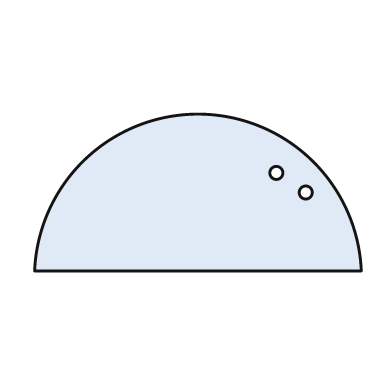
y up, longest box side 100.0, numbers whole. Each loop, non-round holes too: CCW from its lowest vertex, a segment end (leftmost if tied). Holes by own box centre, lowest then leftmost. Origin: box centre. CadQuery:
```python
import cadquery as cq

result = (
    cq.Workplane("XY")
    .moveTo(-50.0, -24.0)
    .lineTo(50.0, -24.0)
    .threePointArc((0.0, 24.0), (-50.0, -24.0))
    .close()
    .moveTo(33.0, 0.0)
    .circle(2.0)
    .moveTo(24.0, 6.0)
    .circle(2.0)
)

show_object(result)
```